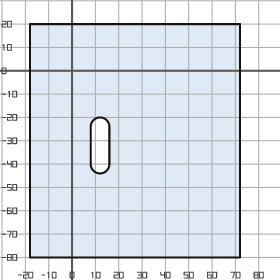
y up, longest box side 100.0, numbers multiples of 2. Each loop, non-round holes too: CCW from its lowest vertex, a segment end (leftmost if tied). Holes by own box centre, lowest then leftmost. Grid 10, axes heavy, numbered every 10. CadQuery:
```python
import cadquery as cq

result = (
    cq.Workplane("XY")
    .moveTo(-18.0, -80.0)
    .lineTo(72.0, -80.0)
    .lineTo(72.0, 20.0)
    .lineTo(-18.0, 20.0)
    .close()
    .moveTo(8.0, -40.0)
    .threePointArc((12.0, -44.0), (16.0, -40.0))
    .lineTo(16.0, -24.0)
    .threePointArc((12.0, -20.0), (8.0, -24.0))
    .close()
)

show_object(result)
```